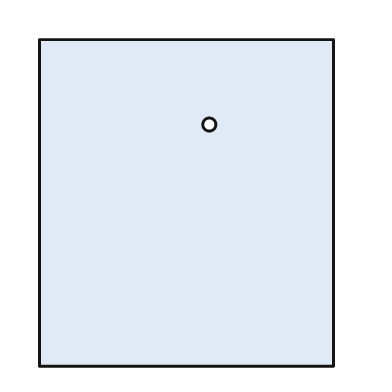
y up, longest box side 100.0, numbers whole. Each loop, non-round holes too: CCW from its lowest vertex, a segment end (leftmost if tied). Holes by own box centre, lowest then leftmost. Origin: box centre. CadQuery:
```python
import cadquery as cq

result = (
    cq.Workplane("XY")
    .moveTo(-45.0, -50.0)
    .lineTo(45.0, -50.0)
    .lineTo(45.0, 50.0)
    .lineTo(-45.0, 50.0)
    .close()
    .moveTo(7.0, 24.0)
    .circle(2.0)
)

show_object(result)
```